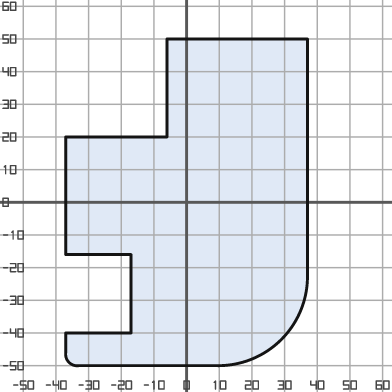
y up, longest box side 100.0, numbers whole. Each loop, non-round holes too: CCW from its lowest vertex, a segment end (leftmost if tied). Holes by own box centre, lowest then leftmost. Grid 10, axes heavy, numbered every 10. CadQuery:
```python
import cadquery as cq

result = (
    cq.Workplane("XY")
    .moveTo(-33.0, -50.0)
    .lineTo(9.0, -50.0)
    .threePointArc((29.0, -42.0), (37.0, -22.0))
    .lineTo(37.0, 50.0)
    .lineTo(-6.0, 50.0)
    .lineTo(-6.0, 20.0)
    .lineTo(-37.0, 20.0)
    .lineTo(-37.0, -16.0)
    .lineTo(-17.0, -16.0)
    .lineTo(-17.0, -40.0)
    .lineTo(-37.0, -40.0)
    .lineTo(-37.0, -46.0)
    .threePointArc((-36.0, -49.0), (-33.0, -50.0))
    .close()
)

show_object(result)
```